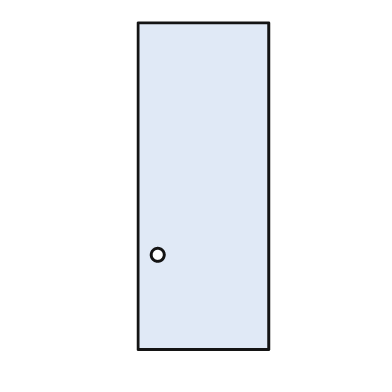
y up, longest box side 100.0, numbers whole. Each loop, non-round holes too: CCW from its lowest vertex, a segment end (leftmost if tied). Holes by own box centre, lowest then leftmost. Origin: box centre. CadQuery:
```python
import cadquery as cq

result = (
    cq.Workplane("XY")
    .moveTo(-20.0, -50.0)
    .lineTo(20.0, -50.0)
    .lineTo(20.0, 50.0)
    .lineTo(-20.0, 50.0)
    .close()
    .moveTo(-14.0, -21.0)
    .circle(2.0)
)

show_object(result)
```